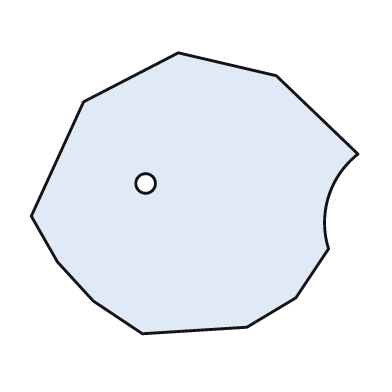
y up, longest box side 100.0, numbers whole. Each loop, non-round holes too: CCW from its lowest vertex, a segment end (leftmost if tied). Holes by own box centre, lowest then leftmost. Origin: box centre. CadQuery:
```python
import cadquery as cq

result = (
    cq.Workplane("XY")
    .moveTo(-16.0, -43.0)
    .lineTo(16.0, -41.0)
    .lineTo(31.0, -32.0)
    .lineTo(41.0, -17.0)
    .threePointArc((41.0, -1.0), (50.0, 12.0))
    .lineTo(25.0, 36.0)
    .lineTo(-5.0, 43.0)
    .lineTo(-34.0, 28.0)
    .lineTo(-50.0, -7.0)
    .lineTo(-42.0, -21.0)
    .lineTo(-31.0, -33.0)
    .close()
    .moveTo(-15.0, 3.0)
    .circle(3.0)
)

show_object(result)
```